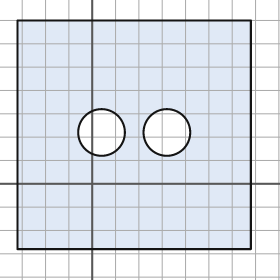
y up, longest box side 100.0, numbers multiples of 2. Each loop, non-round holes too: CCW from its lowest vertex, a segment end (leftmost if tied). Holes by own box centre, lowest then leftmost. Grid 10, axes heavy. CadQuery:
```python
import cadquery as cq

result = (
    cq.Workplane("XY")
    .moveTo(-32.0, -28.0)
    .lineTo(68.0, -28.0)
    .lineTo(68.0, 70.0)
    .lineTo(-32.0, 70.0)
    .close()
    .moveTo(4.0, 22.0)
    .circle(10.0)
    .moveTo(32.0, 22.0)
    .circle(10.0)
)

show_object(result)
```